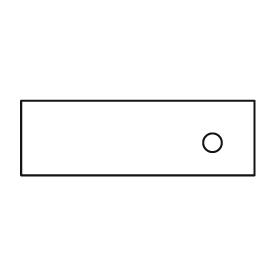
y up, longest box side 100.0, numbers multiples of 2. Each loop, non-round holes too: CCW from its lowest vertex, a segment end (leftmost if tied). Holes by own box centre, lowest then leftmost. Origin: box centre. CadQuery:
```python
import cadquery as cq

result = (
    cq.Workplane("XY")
    .moveTo(-50.0, -16.0)
    .lineTo(50.0, -16.0)
    .lineTo(50.0, 16.0)
    .lineTo(-50.0, 16.0)
    .close()
    .moveTo(32.0, -2.0)
    .circle(4.0)
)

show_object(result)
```